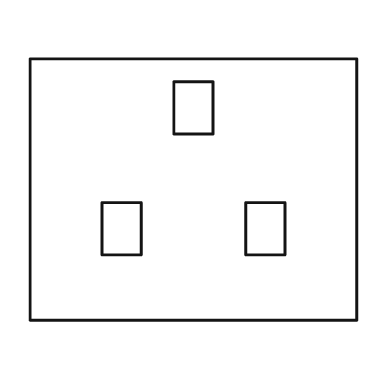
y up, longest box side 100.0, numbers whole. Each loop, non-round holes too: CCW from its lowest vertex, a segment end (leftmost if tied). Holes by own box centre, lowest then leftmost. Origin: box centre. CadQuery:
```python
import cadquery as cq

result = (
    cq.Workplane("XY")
    .moveTo(-50.0, -40.0)
    .lineTo(50.0, -40.0)
    .lineTo(50.0, 40.0)
    .lineTo(-50.0, 40.0)
    .close()
    .moveTo(-28.0, -20.0)
    .lineTo(-16.0, -20.0)
    .lineTo(-16.0, -4.0)
    .lineTo(-28.0, -4.0)
    .close()
    .moveTo(16.0, -20.0)
    .lineTo(28.0, -20.0)
    .lineTo(28.0, -4.0)
    .lineTo(16.0, -4.0)
    .close()
    .moveTo(-6.0, 17.0)
    .lineTo(6.0, 17.0)
    .lineTo(6.0, 33.0)
    .lineTo(-6.0, 33.0)
    .close()
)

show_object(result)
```